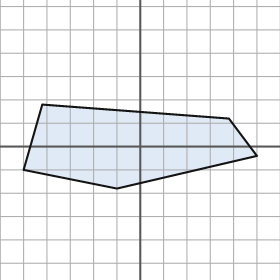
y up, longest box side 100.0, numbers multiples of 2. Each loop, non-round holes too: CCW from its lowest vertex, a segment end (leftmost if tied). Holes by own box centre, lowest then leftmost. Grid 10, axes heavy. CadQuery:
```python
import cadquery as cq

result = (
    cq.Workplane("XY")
    .moveTo(-10.0, -18.0)
    .lineTo(50.0, -4.0)
    .lineTo(38.0, 12.0)
    .lineTo(-42.0, 18.0)
    .lineTo(-50.0, -10.0)
    .close()
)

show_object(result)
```